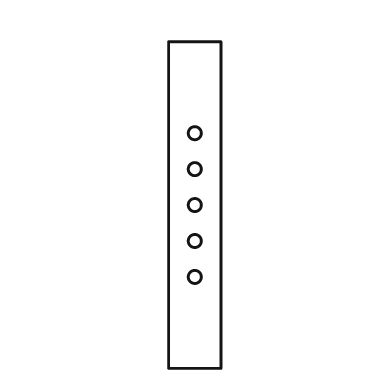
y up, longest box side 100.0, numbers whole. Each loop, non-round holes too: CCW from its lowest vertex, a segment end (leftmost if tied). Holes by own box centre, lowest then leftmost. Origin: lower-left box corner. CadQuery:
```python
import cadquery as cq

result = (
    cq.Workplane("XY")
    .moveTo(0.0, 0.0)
    .lineTo(16.0, 0.0)
    .lineTo(16.0, 100.0)
    .lineTo(0.0, 100.0)
    .close()
    .moveTo(8.0, 28.0)
    .circle(2.0)
    .moveTo(8.0, 39.0)
    .circle(2.0)
    .moveTo(8.0, 50.0)
    .circle(2.0)
    .moveTo(8.0, 61.0)
    .circle(2.0)
    .moveTo(8.0, 72.0)
    .circle(2.0)
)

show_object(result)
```